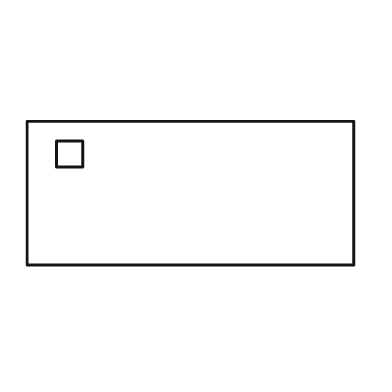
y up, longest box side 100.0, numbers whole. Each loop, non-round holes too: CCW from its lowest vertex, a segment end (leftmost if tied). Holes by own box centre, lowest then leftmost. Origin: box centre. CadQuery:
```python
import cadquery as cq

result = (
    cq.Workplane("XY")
    .moveTo(-50.0, -22.0)
    .lineTo(50.0, -22.0)
    .lineTo(50.0, 22.0)
    .lineTo(-50.0, 22.0)
    .close()
    .moveTo(-41.0, 8.0)
    .lineTo(-33.0, 8.0)
    .lineTo(-33.0, 16.0)
    .lineTo(-41.0, 16.0)
    .close()
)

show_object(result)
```